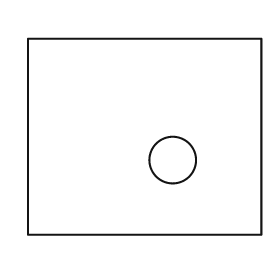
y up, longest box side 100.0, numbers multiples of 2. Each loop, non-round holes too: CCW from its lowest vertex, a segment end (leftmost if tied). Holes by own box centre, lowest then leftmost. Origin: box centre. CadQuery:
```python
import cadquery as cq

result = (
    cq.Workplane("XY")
    .moveTo(-50.0, -42.0)
    .lineTo(50.0, -42.0)
    .lineTo(50.0, 42.0)
    .lineTo(-50.0, 42.0)
    .close()
    .moveTo(12.0, -10.0)
    .circle(10.0)
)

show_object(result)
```